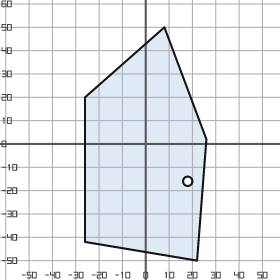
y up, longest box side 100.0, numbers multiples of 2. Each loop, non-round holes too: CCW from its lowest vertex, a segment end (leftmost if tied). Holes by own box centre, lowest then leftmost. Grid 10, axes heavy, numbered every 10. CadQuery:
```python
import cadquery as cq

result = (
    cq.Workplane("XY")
    .moveTo(22.0, -50.0)
    .lineTo(26.0, 2.0)
    .lineTo(8.0, 50.0)
    .lineTo(-26.0, 20.0)
    .lineTo(-26.0, -42.0)
    .close()
    .moveTo(18.0, -16.0)
    .circle(2.0)
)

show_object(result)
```